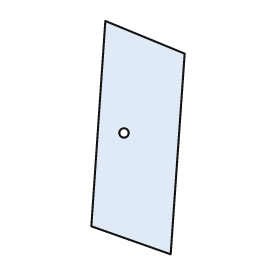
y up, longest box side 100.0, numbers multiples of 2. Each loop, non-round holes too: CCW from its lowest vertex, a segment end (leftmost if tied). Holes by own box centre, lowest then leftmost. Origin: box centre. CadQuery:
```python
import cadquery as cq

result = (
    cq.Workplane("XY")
    .moveTo(14.0, -50.0)
    .lineTo(20.0, 36.0)
    .lineTo(-14.0, 50.0)
    .lineTo(-20.0, -38.0)
    .close()
    .moveTo(-6.0, 2.0)
    .circle(2.0)
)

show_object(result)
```